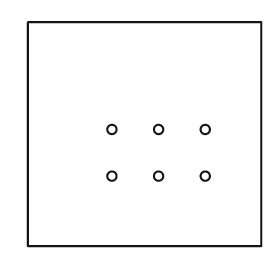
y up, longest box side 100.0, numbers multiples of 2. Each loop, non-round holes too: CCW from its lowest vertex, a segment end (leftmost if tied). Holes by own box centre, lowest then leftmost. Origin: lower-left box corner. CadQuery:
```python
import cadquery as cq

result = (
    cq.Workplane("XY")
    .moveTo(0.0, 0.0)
    .lineTo(100.0, 0.0)
    .lineTo(100.0, 96.0)
    .lineTo(0.0, 96.0)
    .close()
    .moveTo(36.0, 30.0)
    .circle(2.0)
    .moveTo(56.0, 30.0)
    .circle(2.0)
    .moveTo(76.0, 30.0)
    .circle(2.0)
    .moveTo(36.0, 50.0)
    .circle(2.0)
    .moveTo(56.0, 50.0)
    .circle(2.0)
    .moveTo(76.0, 50.0)
    .circle(2.0)
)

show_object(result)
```